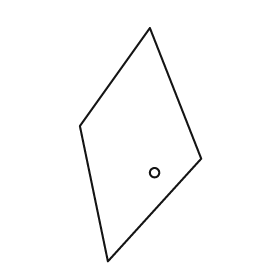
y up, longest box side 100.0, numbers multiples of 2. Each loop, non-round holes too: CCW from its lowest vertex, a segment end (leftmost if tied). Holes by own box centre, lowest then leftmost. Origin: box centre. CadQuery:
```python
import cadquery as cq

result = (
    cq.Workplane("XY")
    .moveTo(-14.0, -50.0)
    .lineTo(26.0, -6.0)
    .lineTo(4.0, 50.0)
    .lineTo(-26.0, 8.0)
    .close()
    .moveTo(6.0, -12.0)
    .circle(2.0)
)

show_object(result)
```